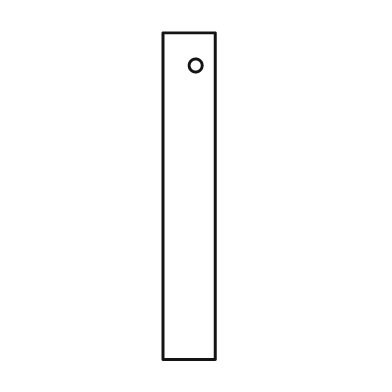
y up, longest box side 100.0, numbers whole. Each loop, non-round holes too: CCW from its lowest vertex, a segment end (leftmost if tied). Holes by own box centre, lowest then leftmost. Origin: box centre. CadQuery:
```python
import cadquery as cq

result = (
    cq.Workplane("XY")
    .moveTo(-8.0, -50.0)
    .lineTo(8.0, -50.0)
    .lineTo(8.0, 50.0)
    .lineTo(-8.0, 50.0)
    .close()
    .moveTo(2.0, 40.0)
    .circle(2.0)
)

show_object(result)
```